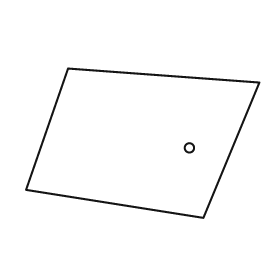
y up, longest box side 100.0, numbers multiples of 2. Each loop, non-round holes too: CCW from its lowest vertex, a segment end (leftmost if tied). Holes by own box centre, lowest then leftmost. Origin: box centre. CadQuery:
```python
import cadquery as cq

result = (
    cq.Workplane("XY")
    .moveTo(26.0, -32.0)
    .lineTo(50.0, 26.0)
    .lineTo(-32.0, 32.0)
    .lineTo(-50.0, -20.0)
    .close()
    .moveTo(20.0, -2.0)
    .circle(2.0)
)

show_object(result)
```